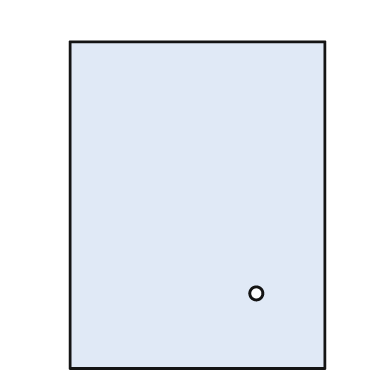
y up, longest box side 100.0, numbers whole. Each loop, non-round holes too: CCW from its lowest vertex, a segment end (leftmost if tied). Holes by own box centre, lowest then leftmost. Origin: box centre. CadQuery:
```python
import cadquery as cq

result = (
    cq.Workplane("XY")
    .moveTo(-39.0, -50.0)
    .lineTo(39.0, -50.0)
    .lineTo(39.0, 50.0)
    .lineTo(-39.0, 50.0)
    .close()
    .moveTo(18.0, -27.0)
    .circle(2.0)
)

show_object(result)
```